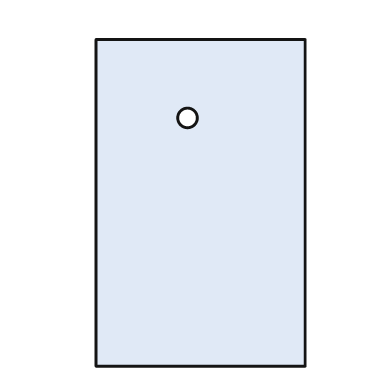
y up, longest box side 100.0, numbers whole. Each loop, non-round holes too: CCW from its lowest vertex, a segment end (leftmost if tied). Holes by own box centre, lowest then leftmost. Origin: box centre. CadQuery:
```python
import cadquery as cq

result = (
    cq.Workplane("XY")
    .moveTo(-32.0, -50.0)
    .lineTo(32.0, -50.0)
    .lineTo(32.0, 50.0)
    .lineTo(-32.0, 50.0)
    .close()
    .moveTo(-4.0, 26.0)
    .circle(3.0)
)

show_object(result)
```